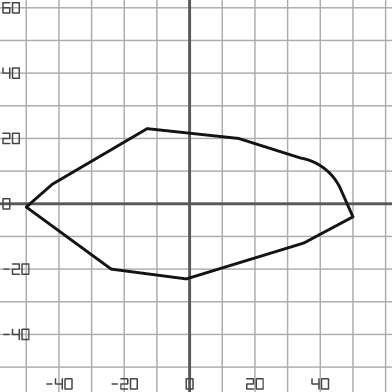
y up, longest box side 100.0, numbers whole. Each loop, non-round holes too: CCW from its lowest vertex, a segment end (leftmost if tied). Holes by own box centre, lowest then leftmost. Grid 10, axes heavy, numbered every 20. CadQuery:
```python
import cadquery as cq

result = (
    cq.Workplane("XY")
    .moveTo(-1.0, -23.0)
    .lineTo(35.0, -12.0)
    .lineTo(50.0, -4.0)
    .lineTo(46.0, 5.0)
    .threePointArc((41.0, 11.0), (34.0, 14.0))
    .lineTo(15.0, 20.0)
    .lineTo(-13.0, 23.0)
    .lineTo(-42.0, 6.0)
    .lineTo(-50.0, -1.0)
    .lineTo(-24.0, -20.0)
    .close()
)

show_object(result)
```